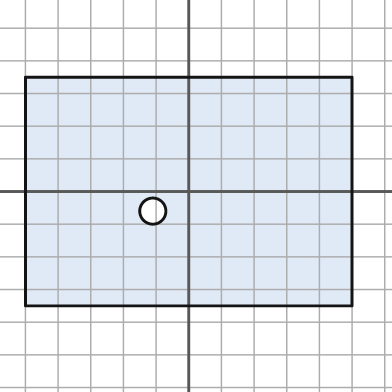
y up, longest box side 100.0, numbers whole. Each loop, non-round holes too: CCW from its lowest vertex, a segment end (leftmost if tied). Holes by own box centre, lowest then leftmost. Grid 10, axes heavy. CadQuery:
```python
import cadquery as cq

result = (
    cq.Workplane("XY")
    .moveTo(-50.0, -35.0)
    .lineTo(50.0, -35.0)
    .lineTo(50.0, 35.0)
    .lineTo(-50.0, 35.0)
    .close()
    .moveTo(-11.0, -6.0)
    .circle(4.0)
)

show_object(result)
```